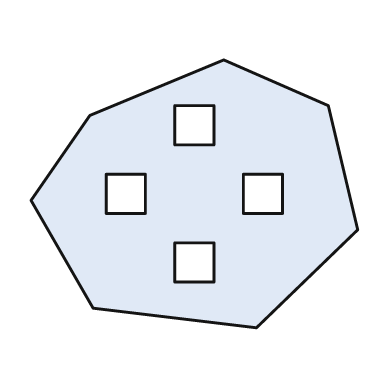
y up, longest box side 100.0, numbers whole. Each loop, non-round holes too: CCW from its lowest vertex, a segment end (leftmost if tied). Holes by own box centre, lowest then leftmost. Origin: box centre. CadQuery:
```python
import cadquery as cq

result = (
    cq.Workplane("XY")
    .moveTo(19.0, -41.0)
    .lineTo(50.0, -11.0)
    .lineTo(41.0, 27.0)
    .lineTo(9.0, 41.0)
    .lineTo(-32.0, 24.0)
    .lineTo(-50.0, -2.0)
    .lineTo(-31.0, -35.0)
    .close()
    .moveTo(-6.0, -27.0)
    .lineTo(6.0, -27.0)
    .lineTo(6.0, -15.0)
    .lineTo(-6.0, -15.0)
    .close()
    .moveTo(-27.0, -6.0)
    .lineTo(-15.0, -6.0)
    .lineTo(-15.0, 6.0)
    .lineTo(-27.0, 6.0)
    .close()
    .moveTo(15.0, -6.0)
    .lineTo(27.0, -6.0)
    .lineTo(27.0, 6.0)
    .lineTo(15.0, 6.0)
    .close()
    .moveTo(-6.0, 15.0)
    .lineTo(6.0, 15.0)
    .lineTo(6.0, 27.0)
    .lineTo(-6.0, 27.0)
    .close()
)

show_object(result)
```